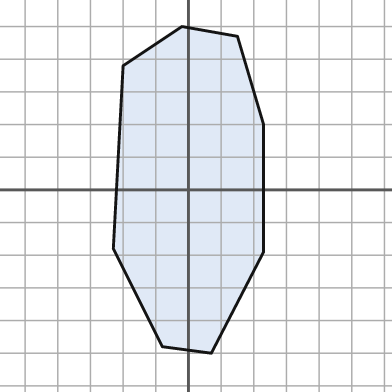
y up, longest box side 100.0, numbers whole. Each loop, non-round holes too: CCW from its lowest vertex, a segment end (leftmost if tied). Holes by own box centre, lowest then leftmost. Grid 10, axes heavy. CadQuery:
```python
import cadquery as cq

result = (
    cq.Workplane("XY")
    .moveTo(7.0, -50.0)
    .lineTo(23.0, -19.0)
    .lineTo(23.0, 20.0)
    .lineTo(15.0, 47.0)
    .lineTo(-2.0, 50.0)
    .lineTo(-20.0, 38.0)
    .lineTo(-23.0, -18.0)
    .lineTo(-8.0, -48.0)
    .close()
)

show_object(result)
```